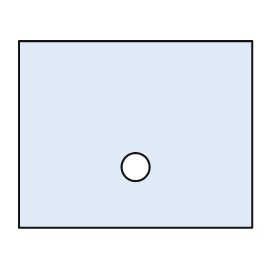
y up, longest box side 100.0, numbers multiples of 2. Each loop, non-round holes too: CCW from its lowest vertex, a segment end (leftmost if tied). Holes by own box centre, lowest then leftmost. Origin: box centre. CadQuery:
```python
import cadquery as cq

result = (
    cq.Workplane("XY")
    .moveTo(-50.0, -40.0)
    .lineTo(50.0, -40.0)
    .lineTo(50.0, 40.0)
    .lineTo(-50.0, 40.0)
    .close()
    .moveTo(0.0, -14.0)
    .circle(6.0)
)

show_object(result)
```